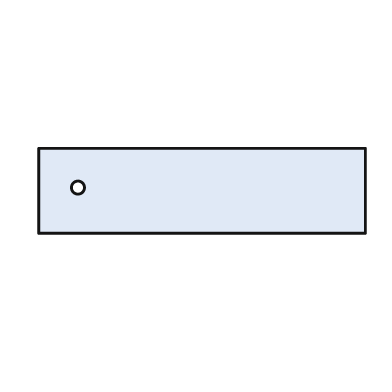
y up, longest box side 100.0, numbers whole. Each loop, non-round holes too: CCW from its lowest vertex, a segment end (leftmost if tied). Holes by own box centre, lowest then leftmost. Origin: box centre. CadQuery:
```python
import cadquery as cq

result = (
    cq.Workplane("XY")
    .moveTo(-50.0, -13.0)
    .lineTo(50.0, -13.0)
    .lineTo(50.0, 13.0)
    .lineTo(-50.0, 13.0)
    .close()
    .moveTo(-38.0, 1.0)
    .circle(2.0)
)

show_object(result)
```